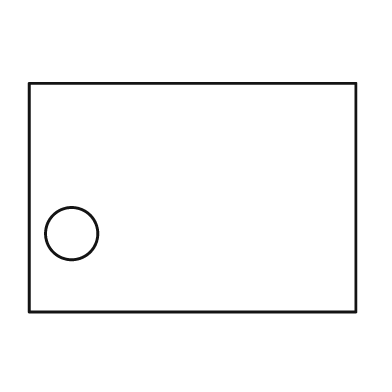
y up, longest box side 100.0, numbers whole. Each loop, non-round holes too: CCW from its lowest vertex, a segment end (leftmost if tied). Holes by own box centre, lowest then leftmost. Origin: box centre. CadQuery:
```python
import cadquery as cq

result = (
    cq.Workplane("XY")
    .moveTo(-50.0, -35.0)
    .lineTo(50.0, -35.0)
    .lineTo(50.0, 35.0)
    .lineTo(-50.0, 35.0)
    .close()
    .moveTo(-37.0, -11.0)
    .circle(8.0)
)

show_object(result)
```